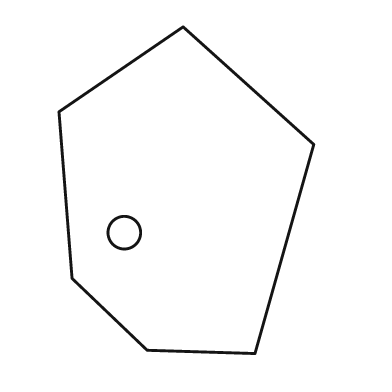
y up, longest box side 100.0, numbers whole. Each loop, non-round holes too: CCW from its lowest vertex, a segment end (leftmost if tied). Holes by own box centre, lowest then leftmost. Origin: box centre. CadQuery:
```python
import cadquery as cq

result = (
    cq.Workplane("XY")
    .moveTo(21.0, -50.0)
    .lineTo(39.0, 14.0)
    .lineTo(-1.0, 50.0)
    .lineTo(-39.0, 24.0)
    .lineTo(-35.0, -27.0)
    .lineTo(-12.0, -49.0)
    .close()
    .moveTo(-19.0, -13.0)
    .circle(5.0)
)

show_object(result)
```